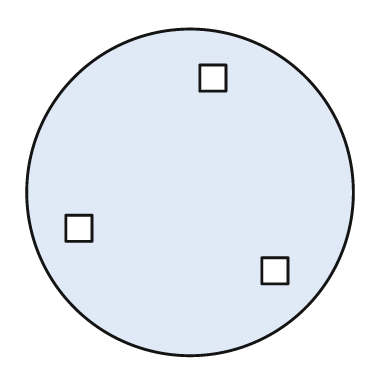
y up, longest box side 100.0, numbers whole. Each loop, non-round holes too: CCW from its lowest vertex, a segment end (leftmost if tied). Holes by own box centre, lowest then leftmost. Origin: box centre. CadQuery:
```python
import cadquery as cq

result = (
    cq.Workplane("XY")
    .moveTo(0.0, 0.0)
    .circle(50.0)
    .moveTo(22.0, -28.0)
    .lineTo(30.0, -28.0)
    .lineTo(30.0, -20.0)
    .lineTo(22.0, -20.0)
    .close()
    .moveTo(-38.0, -15.0)
    .lineTo(-30.0, -15.0)
    .lineTo(-30.0, -7.0)
    .lineTo(-38.0, -7.0)
    .close()
    .moveTo(3.0, 31.0)
    .lineTo(11.0, 31.0)
    .lineTo(11.0, 39.0)
    .lineTo(3.0, 39.0)
    .close()
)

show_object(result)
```